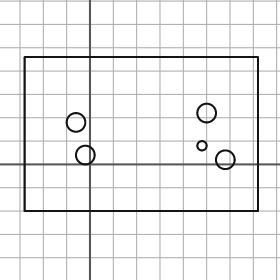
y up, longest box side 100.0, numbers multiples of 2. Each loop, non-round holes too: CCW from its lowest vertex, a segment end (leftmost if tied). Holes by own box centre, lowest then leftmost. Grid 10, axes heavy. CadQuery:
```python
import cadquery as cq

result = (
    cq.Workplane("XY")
    .moveTo(-28.0, -20.0)
    .lineTo(72.0, -20.0)
    .lineTo(72.0, 46.0)
    .lineTo(-28.0, 46.0)
    .close()
    .moveTo(58.0, 2.0)
    .circle(4.0)
    .moveTo(-2.0, 4.0)
    .circle(4.0)
    .moveTo(48.0, 8.0)
    .circle(2.0)
    .moveTo(-6.0, 18.0)
    .circle(4.0)
    .moveTo(50.0, 22.0)
    .circle(4.0)
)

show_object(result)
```